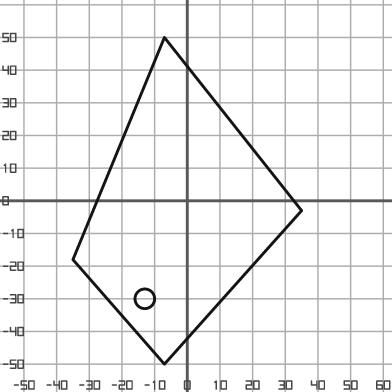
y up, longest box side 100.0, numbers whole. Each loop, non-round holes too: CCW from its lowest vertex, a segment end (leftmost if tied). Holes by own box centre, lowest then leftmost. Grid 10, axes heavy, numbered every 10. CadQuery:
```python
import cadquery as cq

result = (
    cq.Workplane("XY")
    .moveTo(-7.0, -50.0)
    .lineTo(35.0, -3.0)
    .lineTo(-7.0, 50.0)
    .lineTo(-35.0, -18.0)
    .close()
    .moveTo(-13.0, -30.0)
    .circle(3.0)
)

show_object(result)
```